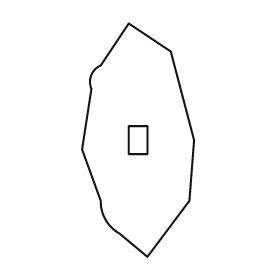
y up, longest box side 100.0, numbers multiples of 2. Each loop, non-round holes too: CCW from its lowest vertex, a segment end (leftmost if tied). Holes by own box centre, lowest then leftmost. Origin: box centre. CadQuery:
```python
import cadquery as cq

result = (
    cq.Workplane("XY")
    .moveTo(4.0, -50.0)
    .lineTo(22.0, -26.0)
    .lineTo(24.0, 0.0)
    .lineTo(14.0, 38.0)
    .lineTo(-4.0, 50.0)
    .lineTo(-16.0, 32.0)
    .threePointArc((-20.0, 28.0), (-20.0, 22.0))
    .lineTo(-24.0, -4.0)
    .lineTo(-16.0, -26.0)
    .threePointArc((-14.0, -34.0), (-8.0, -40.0))
    .close()
    .moveTo(-4.0, -6.0)
    .lineTo(4.0, -6.0)
    .lineTo(4.0, 6.0)
    .lineTo(-4.0, 6.0)
    .close()
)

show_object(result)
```